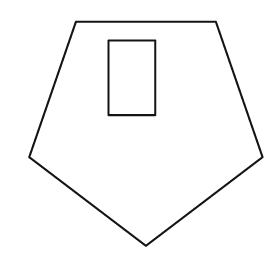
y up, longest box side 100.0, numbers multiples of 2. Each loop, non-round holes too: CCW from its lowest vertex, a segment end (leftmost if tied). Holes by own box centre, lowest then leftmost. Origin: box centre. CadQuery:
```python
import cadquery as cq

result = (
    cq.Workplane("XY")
    .moveTo(0.0, -48.0)
    .lineTo(50.0, -10.0)
    .lineTo(30.0, 48.0)
    .lineTo(-30.0, 48.0)
    .lineTo(-50.0, -10.0)
    .close()
    .moveTo(-16.0, 8.0)
    .lineTo(4.0, 8.0)
    .lineTo(4.0, 40.0)
    .lineTo(-16.0, 40.0)
    .close()
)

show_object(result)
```